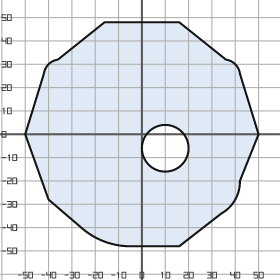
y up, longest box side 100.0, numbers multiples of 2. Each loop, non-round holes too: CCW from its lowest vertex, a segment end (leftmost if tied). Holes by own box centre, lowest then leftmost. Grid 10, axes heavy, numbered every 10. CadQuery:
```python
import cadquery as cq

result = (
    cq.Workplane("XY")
    .moveTo(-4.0, -48.0)
    .lineTo(16.0, -48.0)
    .lineTo(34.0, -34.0)
    .threePointArc((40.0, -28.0), (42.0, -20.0))
    .lineTo(50.0, 0.0)
    .lineTo(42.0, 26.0)
    .threePointArc((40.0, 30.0), (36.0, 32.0))
    .lineTo(16.0, 48.0)
    .lineTo(-16.0, 48.0)
    .lineTo(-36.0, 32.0)
    .threePointArc((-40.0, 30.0), (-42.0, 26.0))
    .lineTo(-50.0, 0.0)
    .lineTo(-40.0, -28.0)
    .lineTo(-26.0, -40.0)
    .threePointArc((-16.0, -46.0), (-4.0, -48.0))
    .close()
    .moveTo(10.0, -6.0)
    .circle(10.0)
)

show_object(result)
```